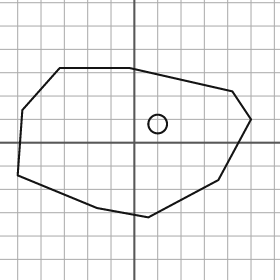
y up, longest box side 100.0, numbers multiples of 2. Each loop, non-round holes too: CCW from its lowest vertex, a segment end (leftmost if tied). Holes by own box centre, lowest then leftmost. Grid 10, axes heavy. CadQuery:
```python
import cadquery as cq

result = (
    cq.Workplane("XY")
    .moveTo(6.0, -32.0)
    .lineTo(36.0, -16.0)
    .lineTo(50.0, 10.0)
    .lineTo(42.0, 22.0)
    .lineTo(-2.0, 32.0)
    .lineTo(-32.0, 32.0)
    .lineTo(-48.0, 14.0)
    .lineTo(-50.0, -14.0)
    .lineTo(-16.0, -28.0)
    .close()
    .moveTo(10.0, 8.0)
    .circle(4.0)
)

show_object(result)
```